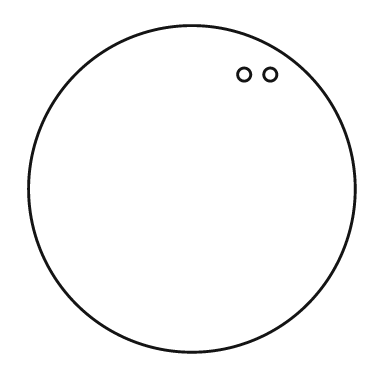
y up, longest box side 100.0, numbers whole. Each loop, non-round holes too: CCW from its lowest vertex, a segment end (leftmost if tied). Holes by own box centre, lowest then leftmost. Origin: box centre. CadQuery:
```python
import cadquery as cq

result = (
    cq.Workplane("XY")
    .moveTo(0.0, 0.0)
    .circle(50.0)
    .moveTo(16.0, 35.0)
    .circle(2.0)
    .moveTo(24.0, 35.0)
    .circle(2.0)
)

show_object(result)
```